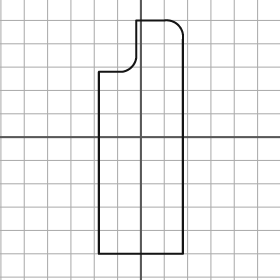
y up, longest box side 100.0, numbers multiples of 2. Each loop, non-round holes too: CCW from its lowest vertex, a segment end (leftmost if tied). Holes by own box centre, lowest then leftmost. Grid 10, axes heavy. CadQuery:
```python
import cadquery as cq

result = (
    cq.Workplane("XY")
    .moveTo(-18.0, -50.0)
    .lineTo(18.0, -50.0)
    .lineTo(18.0, 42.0)
    .threePointArc((16.0, 48.0), (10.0, 50.0))
    .lineTo(-2.0, 50.0)
    .lineTo(-2.0, 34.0)
    .threePointArc((-4.0, 30.0), (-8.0, 28.0))
    .lineTo(-18.0, 28.0)
    .close()
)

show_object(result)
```